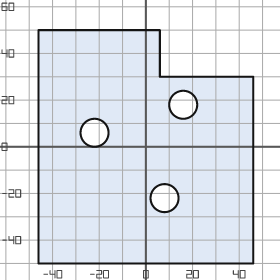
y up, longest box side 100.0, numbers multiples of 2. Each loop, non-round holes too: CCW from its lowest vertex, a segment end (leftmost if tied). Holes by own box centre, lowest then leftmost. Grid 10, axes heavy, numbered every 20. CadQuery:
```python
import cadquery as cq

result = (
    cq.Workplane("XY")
    .moveTo(-46.0, -50.0)
    .lineTo(46.0, -50.0)
    .lineTo(46.0, 30.0)
    .lineTo(6.0, 30.0)
    .lineTo(6.0, 50.0)
    .lineTo(-46.0, 50.0)
    .close()
    .moveTo(8.0, -22.0)
    .circle(6.0)
    .moveTo(-22.0, 6.0)
    .circle(6.0)
    .moveTo(16.0, 18.0)
    .circle(6.0)
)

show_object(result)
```